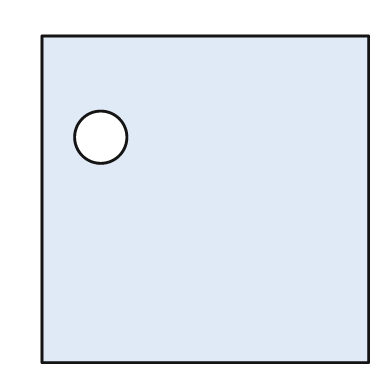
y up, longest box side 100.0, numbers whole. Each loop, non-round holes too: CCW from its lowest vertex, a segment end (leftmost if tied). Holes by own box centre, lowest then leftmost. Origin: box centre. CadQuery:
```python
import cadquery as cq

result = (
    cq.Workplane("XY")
    .moveTo(-50.0, -50.0)
    .lineTo(50.0, -50.0)
    .lineTo(50.0, 50.0)
    .lineTo(-50.0, 50.0)
    .close()
    .moveTo(-32.0, 19.0)
    .circle(8.0)
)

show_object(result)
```